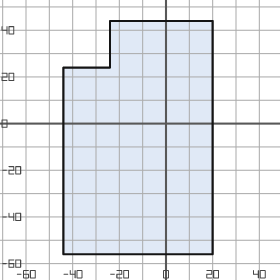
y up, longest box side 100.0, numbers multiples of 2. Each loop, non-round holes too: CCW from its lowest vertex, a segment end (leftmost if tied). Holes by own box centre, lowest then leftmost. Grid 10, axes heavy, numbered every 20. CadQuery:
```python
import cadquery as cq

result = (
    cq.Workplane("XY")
    .moveTo(-44.0, -56.0)
    .lineTo(20.0, -56.0)
    .lineTo(20.0, 44.0)
    .lineTo(-24.0, 44.0)
    .lineTo(-24.0, 24.0)
    .lineTo(-44.0, 24.0)
    .close()
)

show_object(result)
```